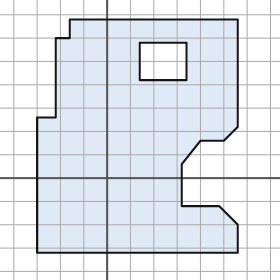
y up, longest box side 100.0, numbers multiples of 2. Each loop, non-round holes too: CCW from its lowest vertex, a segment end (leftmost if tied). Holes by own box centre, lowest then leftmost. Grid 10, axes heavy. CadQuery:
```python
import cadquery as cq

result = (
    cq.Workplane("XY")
    .moveTo(-30.0, -32.0)
    .lineTo(56.0, -32.0)
    .lineTo(56.0, -20.0)
    .lineTo(48.0, -12.0)
    .lineTo(32.0, -12.0)
    .lineTo(32.0, 6.0)
    .lineTo(40.0, 16.0)
    .lineTo(50.0, 16.0)
    .lineTo(56.0, 22.0)
    .lineTo(56.0, 68.0)
    .lineTo(-16.0, 68.0)
    .lineTo(-16.0, 60.0)
    .lineTo(-22.0, 60.0)
    .lineTo(-22.0, 26.0)
    .lineTo(-30.0, 26.0)
    .close()
    .moveTo(14.0, 42.0)
    .lineTo(34.0, 42.0)
    .lineTo(34.0, 58.0)
    .lineTo(14.0, 58.0)
    .close()
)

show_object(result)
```